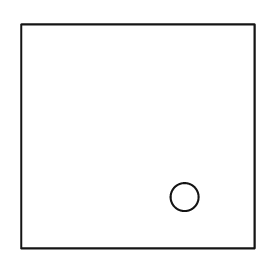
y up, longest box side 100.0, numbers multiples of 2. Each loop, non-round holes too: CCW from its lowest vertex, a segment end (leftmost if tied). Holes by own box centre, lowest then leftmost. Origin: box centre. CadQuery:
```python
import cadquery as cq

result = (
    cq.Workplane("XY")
    .moveTo(-50.0, -48.0)
    .lineTo(50.0, -48.0)
    .lineTo(50.0, 48.0)
    .lineTo(-50.0, 48.0)
    .close()
    .moveTo(20.0, -26.0)
    .circle(6.0)
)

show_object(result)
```